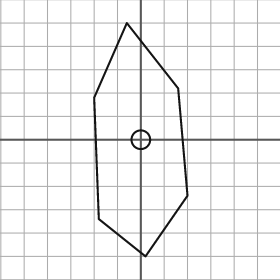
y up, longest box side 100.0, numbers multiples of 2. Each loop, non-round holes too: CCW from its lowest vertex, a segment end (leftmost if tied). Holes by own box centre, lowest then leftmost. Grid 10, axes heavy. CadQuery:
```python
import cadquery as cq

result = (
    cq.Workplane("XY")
    .moveTo(2.0, -50.0)
    .lineTo(20.0, -24.0)
    .lineTo(16.0, 22.0)
    .lineTo(-6.0, 50.0)
    .lineTo(-20.0, 18.0)
    .lineTo(-18.0, -34.0)
    .close()
    .moveTo(0.0, 0.0)
    .circle(4.0)
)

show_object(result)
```